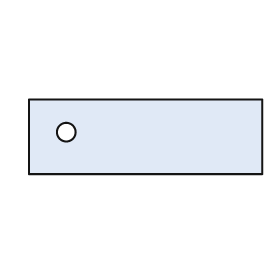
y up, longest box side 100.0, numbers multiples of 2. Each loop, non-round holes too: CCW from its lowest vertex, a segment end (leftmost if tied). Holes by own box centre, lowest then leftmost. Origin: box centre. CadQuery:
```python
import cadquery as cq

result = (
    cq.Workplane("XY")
    .moveTo(-50.0, -16.0)
    .lineTo(50.0, -16.0)
    .lineTo(50.0, 16.0)
    .lineTo(-50.0, 16.0)
    .close()
    .moveTo(-34.0, 2.0)
    .circle(4.0)
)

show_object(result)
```